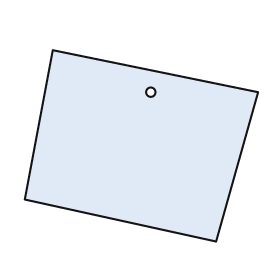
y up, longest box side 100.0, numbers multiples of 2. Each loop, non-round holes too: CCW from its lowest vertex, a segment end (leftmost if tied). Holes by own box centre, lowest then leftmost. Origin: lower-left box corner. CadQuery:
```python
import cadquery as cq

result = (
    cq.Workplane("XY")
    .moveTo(82.0, 0.0)
    .lineTo(100.0, 64.0)
    .lineTo(12.0, 82.0)
    .lineTo(0.0, 18.0)
    .close()
    .moveTo(54.0, 64.0)
    .circle(2.0)
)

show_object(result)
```